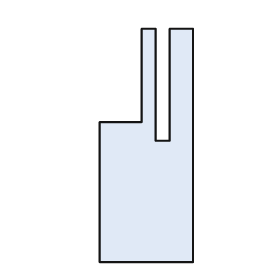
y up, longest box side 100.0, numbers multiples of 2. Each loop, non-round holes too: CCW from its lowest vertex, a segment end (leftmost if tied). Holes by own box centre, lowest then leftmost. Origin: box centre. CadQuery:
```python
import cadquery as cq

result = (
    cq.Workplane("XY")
    .moveTo(-20.0, -50.0)
    .lineTo(20.0, -50.0)
    .lineTo(20.0, 50.0)
    .lineTo(10.0, 50.0)
    .lineTo(10.0, 2.0)
    .lineTo(4.0, 2.0)
    .lineTo(4.0, 50.0)
    .lineTo(-2.0, 50.0)
    .lineTo(-2.0, 10.0)
    .lineTo(-20.0, 10.0)
    .close()
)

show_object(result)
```